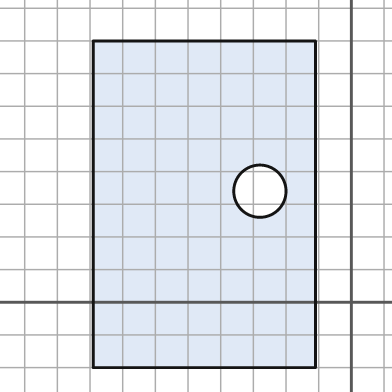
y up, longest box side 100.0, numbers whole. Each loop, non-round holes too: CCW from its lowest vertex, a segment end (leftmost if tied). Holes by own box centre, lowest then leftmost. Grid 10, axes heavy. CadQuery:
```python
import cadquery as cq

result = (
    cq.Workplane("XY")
    .moveTo(-79.0, -20.0)
    .lineTo(-11.0, -20.0)
    .lineTo(-11.0, 80.0)
    .lineTo(-79.0, 80.0)
    .close()
    .moveTo(-28.0, 34.0)
    .circle(8.0)
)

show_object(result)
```